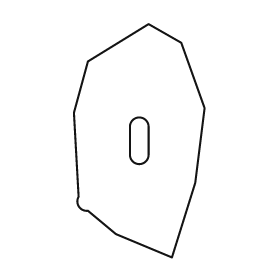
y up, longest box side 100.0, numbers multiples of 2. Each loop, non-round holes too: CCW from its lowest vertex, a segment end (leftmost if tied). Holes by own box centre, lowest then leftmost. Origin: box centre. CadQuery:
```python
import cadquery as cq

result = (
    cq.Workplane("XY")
    .moveTo(14.0, -50.0)
    .lineTo(24.0, -18.0)
    .lineTo(28.0, 14.0)
    .lineTo(18.0, 42.0)
    .lineTo(4.0, 50.0)
    .lineTo(-22.0, 34.0)
    .lineTo(-28.0, 12.0)
    .lineTo(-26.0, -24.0)
    .threePointArc((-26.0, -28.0), (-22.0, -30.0))
    .lineTo(-10.0, -40.0)
    .close()
    .moveTo(-4.0, -6.0)
    .threePointArc((0.0, -10.0), (4.0, -6.0))
    .lineTo(4.0, 6.0)
    .threePointArc((0.0, 10.0), (-4.0, 6.0))
    .close()
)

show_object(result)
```